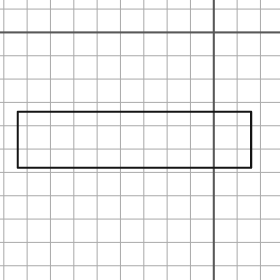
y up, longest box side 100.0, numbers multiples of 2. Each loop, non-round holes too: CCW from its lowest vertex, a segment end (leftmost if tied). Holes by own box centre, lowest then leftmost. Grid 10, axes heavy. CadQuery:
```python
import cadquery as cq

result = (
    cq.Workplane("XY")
    .moveTo(-84.0, -58.0)
    .lineTo(16.0, -58.0)
    .lineTo(16.0, -34.0)
    .lineTo(-84.0, -34.0)
    .close()
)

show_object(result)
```